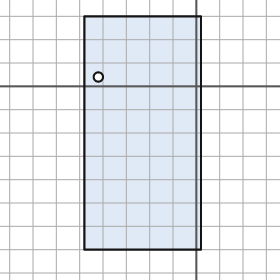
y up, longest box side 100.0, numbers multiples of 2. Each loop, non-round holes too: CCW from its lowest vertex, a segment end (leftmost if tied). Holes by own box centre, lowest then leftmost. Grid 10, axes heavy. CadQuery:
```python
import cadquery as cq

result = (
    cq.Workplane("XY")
    .moveTo(-48.0, -70.0)
    .lineTo(2.0, -70.0)
    .lineTo(2.0, 30.0)
    .lineTo(-48.0, 30.0)
    .close()
    .moveTo(-42.0, 4.0)
    .circle(2.0)
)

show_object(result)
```